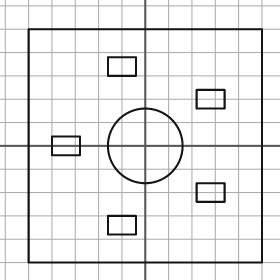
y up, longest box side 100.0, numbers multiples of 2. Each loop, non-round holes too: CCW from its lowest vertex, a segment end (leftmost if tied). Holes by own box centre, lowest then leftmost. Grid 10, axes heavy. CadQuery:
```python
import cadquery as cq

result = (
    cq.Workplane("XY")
    .moveTo(-50.0, -50.0)
    .lineTo(50.0, -50.0)
    .lineTo(50.0, 50.0)
    .lineTo(-50.0, 50.0)
    .close()
    .moveTo(-16.0, -38.0)
    .lineTo(-4.0, -38.0)
    .lineTo(-4.0, -30.0)
    .lineTo(-16.0, -30.0)
    .close()
    .moveTo(22.0, -24.0)
    .lineTo(34.0, -24.0)
    .lineTo(34.0, -16.0)
    .lineTo(22.0, -16.0)
    .close()
    .moveTo(-40.0, -4.0)
    .lineTo(-28.0, -4.0)
    .lineTo(-28.0, 4.0)
    .lineTo(-40.0, 4.0)
    .close()
    .moveTo(0.0, 0.0)
    .circle(16.0)
    .moveTo(22.0, 16.0)
    .lineTo(34.0, 16.0)
    .lineTo(34.0, 24.0)
    .lineTo(22.0, 24.0)
    .close()
    .moveTo(-16.0, 30.0)
    .lineTo(-4.0, 30.0)
    .lineTo(-4.0, 38.0)
    .lineTo(-16.0, 38.0)
    .close()
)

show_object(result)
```